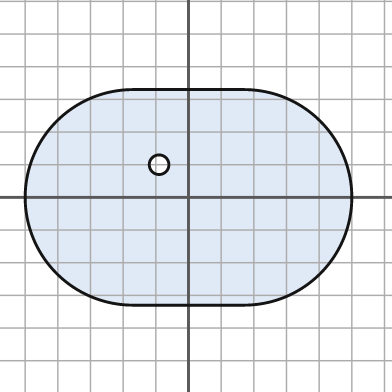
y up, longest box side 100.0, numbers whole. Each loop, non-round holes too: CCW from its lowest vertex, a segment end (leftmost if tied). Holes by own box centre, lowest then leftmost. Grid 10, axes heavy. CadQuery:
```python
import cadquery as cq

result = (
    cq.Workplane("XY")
    .moveTo(-17.0, -33.0)
    .lineTo(17.0, -33.0)
    .threePointArc((50.0, 0.0), (17.0, 33.0))
    .lineTo(-17.0, 33.0)
    .threePointArc((-50.0, 0.0), (-17.0, -33.0))
    .close()
    .moveTo(-9.0, 10.0)
    .circle(3.0)
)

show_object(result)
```